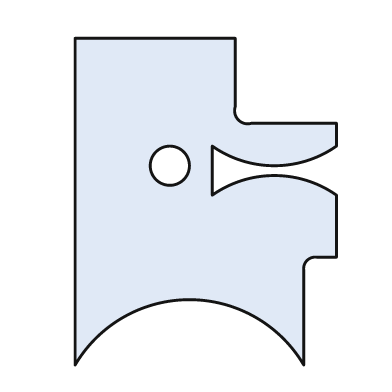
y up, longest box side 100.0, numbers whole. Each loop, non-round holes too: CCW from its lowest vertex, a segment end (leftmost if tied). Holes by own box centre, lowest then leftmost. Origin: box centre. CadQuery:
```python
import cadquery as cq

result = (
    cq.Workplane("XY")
    .moveTo(-40.0, -50.0)
    .threePointArc((-5.0, -30.0), (30.0, -50.0))
    .lineTo(30.0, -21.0)
    .threePointArc((31.0, -18.0), (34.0, -17.0))
    .lineTo(40.0, -17.0)
    .lineTo(40.0, 2.0)
    .threePointArc((21.0, 8.0), (2.0, 2.0))
    .lineTo(2.0, 17.0)
    .threePointArc((21.0, 11.0), (40.0, 17.0))
    .lineTo(40.0, 24.0)
    .lineTo(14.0, 24.0)
    .threePointArc((10.0, 25.0), (9.0, 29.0))
    .lineTo(9.0, 50.0)
    .lineTo(-40.0, 50.0)
    .close()
    .moveTo(-11.0, 11.0)
    .circle(6.0)
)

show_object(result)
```